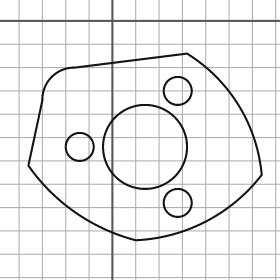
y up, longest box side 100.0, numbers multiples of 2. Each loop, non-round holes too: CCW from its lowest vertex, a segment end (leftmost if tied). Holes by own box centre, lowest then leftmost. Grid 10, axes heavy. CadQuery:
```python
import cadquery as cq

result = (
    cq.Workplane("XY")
    .moveTo(10.0, -94.0)
    .threePointArc((40.0, -86.0), (64.0, -66.0))
    .threePointArc((54.0, -36.0), (32.0, -14.0))
    .lineTo(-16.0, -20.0)
    .threePointArc((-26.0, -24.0), (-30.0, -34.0))
    .lineTo(-36.0, -62.0)
    .threePointArc((-16.0, -82.0), (10.0, -94.0))
    .close()
    .moveTo(28.0, -78.0)
    .circle(6.0)
    .moveTo(-14.0, -54.0)
    .circle(6.0)
    .moveTo(14.0, -54.0)
    .circle(18.0)
    .moveTo(28.0, -30.0)
    .circle(6.0)
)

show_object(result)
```